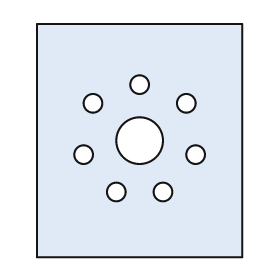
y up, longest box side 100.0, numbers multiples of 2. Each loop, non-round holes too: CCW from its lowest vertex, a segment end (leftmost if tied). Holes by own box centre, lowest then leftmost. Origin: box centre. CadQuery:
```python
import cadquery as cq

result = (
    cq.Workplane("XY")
    .moveTo(-44.0, -50.0)
    .lineTo(44.0, -50.0)
    .lineTo(44.0, 50.0)
    .lineTo(-44.0, 50.0)
    .close()
    .moveTo(-10.0, -22.0)
    .circle(4.0)
    .moveTo(10.0, -22.0)
    .circle(4.0)
    .moveTo(-24.0, -6.0)
    .circle(4.0)
    .moveTo(24.0, -6.0)
    .circle(4.0)
    .moveTo(0.0, 0.0)
    .circle(10.0)
    .moveTo(-20.0, 16.0)
    .circle(4.0)
    .moveTo(20.0, 16.0)
    .circle(4.0)
    .moveTo(0.0, 24.0)
    .circle(4.0)
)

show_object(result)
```